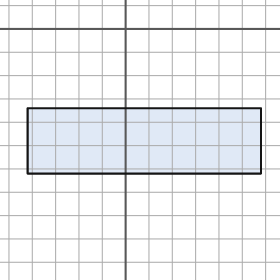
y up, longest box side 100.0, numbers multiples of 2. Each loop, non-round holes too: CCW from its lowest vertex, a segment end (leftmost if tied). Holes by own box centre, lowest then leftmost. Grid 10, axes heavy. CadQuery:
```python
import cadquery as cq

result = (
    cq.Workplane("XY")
    .moveTo(-42.0, -62.0)
    .lineTo(58.0, -62.0)
    .lineTo(58.0, -34.0)
    .lineTo(-42.0, -34.0)
    .close()
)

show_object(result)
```